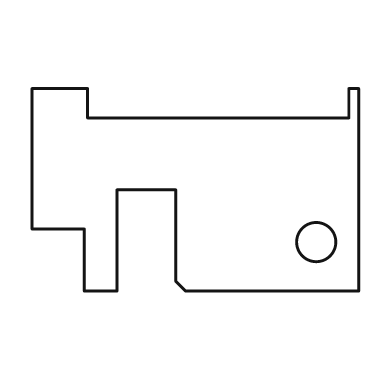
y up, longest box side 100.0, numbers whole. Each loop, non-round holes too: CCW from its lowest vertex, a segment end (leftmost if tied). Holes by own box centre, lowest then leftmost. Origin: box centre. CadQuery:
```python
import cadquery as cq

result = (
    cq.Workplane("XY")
    .moveTo(-34.0, -31.0)
    .lineTo(-24.0, -31.0)
    .lineTo(-24.0, 0.0)
    .lineTo(-6.0, 0.0)
    .lineTo(-6.0, -28.0)
    .lineTo(-3.0, -31.0)
    .lineTo(50.0, -31.0)
    .lineTo(50.0, 31.0)
    .lineTo(47.0, 31.0)
    .lineTo(47.0, 22.0)
    .lineTo(-33.0, 22.0)
    .lineTo(-33.0, 31.0)
    .lineTo(-50.0, 31.0)
    .lineTo(-50.0, -12.0)
    .lineTo(-34.0, -12.0)
    .close()
    .moveTo(37.0, -16.0)
    .circle(6.0)
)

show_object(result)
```